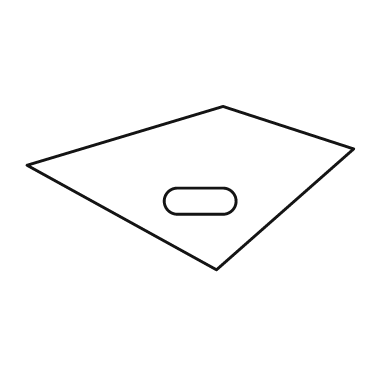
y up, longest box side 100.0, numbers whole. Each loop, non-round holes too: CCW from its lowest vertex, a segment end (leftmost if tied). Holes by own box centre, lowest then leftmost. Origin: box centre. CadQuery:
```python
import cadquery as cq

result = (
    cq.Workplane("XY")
    .moveTo(8.0, -25.0)
    .lineTo(50.0, 12.0)
    .lineTo(10.0, 25.0)
    .lineTo(-50.0, 7.0)
    .close()
    .moveTo(-4.0, -8.0)
    .lineTo(10.0, -8.0)
    .threePointArc((14.0, -4.0), (10.0, 0.0))
    .lineTo(-4.0, 0.0)
    .threePointArc((-8.0, -4.0), (-4.0, -8.0))
    .close()
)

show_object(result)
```